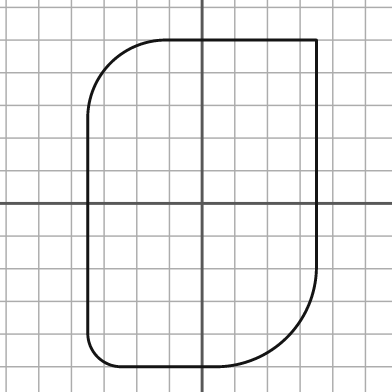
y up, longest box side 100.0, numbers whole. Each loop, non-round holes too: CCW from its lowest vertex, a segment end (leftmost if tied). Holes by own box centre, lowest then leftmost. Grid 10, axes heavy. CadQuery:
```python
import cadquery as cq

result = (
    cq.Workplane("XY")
    .moveTo(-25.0, -50.0)
    .lineTo(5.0, -50.0)
    .threePointArc((26.0, -41.0), (35.0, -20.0))
    .lineTo(35.0, 50.0)
    .lineTo(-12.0, 50.0)
    .threePointArc((-28.0, 43.0), (-35.0, 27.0))
    .lineTo(-35.0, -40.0)
    .threePointArc((-32.0, -47.0), (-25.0, -50.0))
    .close()
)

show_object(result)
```